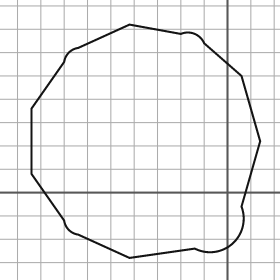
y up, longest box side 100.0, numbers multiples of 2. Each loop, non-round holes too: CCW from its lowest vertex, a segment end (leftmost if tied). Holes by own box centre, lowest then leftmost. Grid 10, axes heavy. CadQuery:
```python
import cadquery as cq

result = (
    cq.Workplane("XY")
    .moveTo(-42.0, -28.0)
    .lineTo(-14.0, -24.0)
    .threePointArc((2.0, -22.0), (6.0, -6.0))
    .lineTo(14.0, 22.0)
    .lineTo(6.0, 50.0)
    .lineTo(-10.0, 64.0)
    .threePointArc((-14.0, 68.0), (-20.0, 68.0))
    .lineTo(-42.0, 72.0)
    .lineTo(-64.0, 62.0)
    .threePointArc((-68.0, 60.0), (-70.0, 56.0))
    .lineTo(-84.0, 36.0)
    .lineTo(-84.0, 8.0)
    .lineTo(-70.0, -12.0)
    .threePointArc((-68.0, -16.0), (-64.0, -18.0))
    .close()
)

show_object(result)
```